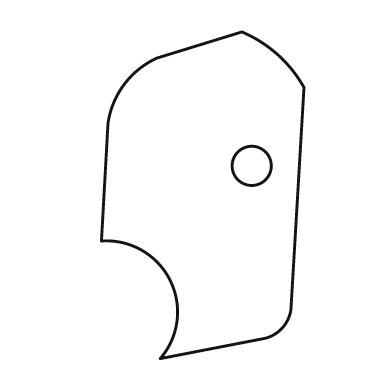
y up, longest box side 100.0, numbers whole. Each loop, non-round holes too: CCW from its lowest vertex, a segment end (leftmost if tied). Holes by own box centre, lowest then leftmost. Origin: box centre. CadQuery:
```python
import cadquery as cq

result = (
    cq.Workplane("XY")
    .moveTo(-13.0, -50.0)
    .lineTo(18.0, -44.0)
    .threePointArc((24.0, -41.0), (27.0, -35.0))
    .lineTo(31.0, 33.0)
    .threePointArc((23.0, 43.0), (12.0, 50.0))
    .lineTo(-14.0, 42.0)
    .threePointArc((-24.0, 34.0), (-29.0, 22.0))
    .lineTo(-31.0, -14.0)
    .threePointArc((-10.0, -26.0), (-13.0, -50.0))
    .close()
    .moveTo(15.0, 9.0)
    .circle(6.0)
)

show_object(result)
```